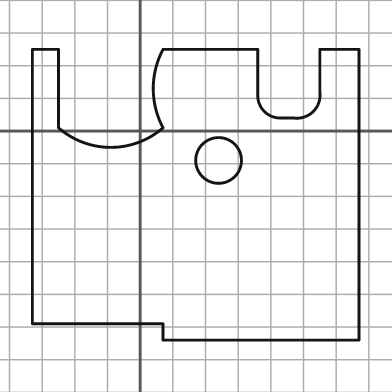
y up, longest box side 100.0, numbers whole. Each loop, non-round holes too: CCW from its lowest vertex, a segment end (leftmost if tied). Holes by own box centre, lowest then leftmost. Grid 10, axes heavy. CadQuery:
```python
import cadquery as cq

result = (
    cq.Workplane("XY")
    .moveTo(7.0, -64.0)
    .lineTo(67.0, -64.0)
    .lineTo(67.0, 25.0)
    .lineTo(55.0, 25.0)
    .lineTo(55.0, 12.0)
    .threePointArc((53.0, 6.0), (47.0, 4.0))
    .lineTo(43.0, 4.0)
    .threePointArc((38.0, 6.0), (36.0, 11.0))
    .lineTo(36.0, 25.0)
    .lineTo(7.0, 25.0)
    .threePointArc((4.0, 13.0), (7.0, 1.0))
    .threePointArc((-9.0, -5.0), (-25.0, 1.0))
    .lineTo(-25.0, 25.0)
    .lineTo(-33.0, 25.0)
    .lineTo(-33.0, -59.0)
    .lineTo(7.0, -59.0)
    .close()
    .moveTo(24.0, -9.0)
    .circle(7.0)
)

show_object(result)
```